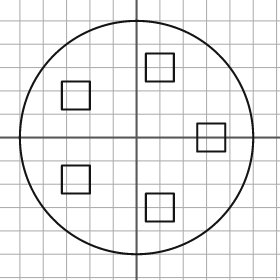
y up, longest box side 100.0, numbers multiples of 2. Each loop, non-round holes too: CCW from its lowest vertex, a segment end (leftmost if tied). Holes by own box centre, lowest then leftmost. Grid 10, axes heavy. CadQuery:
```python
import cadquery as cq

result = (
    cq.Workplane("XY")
    .moveTo(0.0, 0.0)
    .circle(50.0)
    .moveTo(4.0, -36.0)
    .lineTo(16.0, -36.0)
    .lineTo(16.0, -24.0)
    .lineTo(4.0, -24.0)
    .close()
    .moveTo(-32.0, -24.0)
    .lineTo(-20.0, -24.0)
    .lineTo(-20.0, -12.0)
    .lineTo(-32.0, -12.0)
    .close()
    .moveTo(26.0, -6.0)
    .lineTo(38.0, -6.0)
    .lineTo(38.0, 6.0)
    .lineTo(26.0, 6.0)
    .close()
    .moveTo(-32.0, 12.0)
    .lineTo(-20.0, 12.0)
    .lineTo(-20.0, 24.0)
    .lineTo(-32.0, 24.0)
    .close()
    .moveTo(4.0, 24.0)
    .lineTo(16.0, 24.0)
    .lineTo(16.0, 36.0)
    .lineTo(4.0, 36.0)
    .close()
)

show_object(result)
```